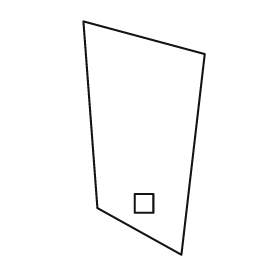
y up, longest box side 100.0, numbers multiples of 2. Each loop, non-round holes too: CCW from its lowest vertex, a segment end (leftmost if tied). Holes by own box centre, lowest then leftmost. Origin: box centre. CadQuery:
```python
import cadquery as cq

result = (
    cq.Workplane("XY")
    .moveTo(16.0, -50.0)
    .lineTo(26.0, 36.0)
    .lineTo(-26.0, 50.0)
    .lineTo(-20.0, -30.0)
    .close()
    .moveTo(-4.0, -32.0)
    .lineTo(4.0, -32.0)
    .lineTo(4.0, -24.0)
    .lineTo(-4.0, -24.0)
    .close()
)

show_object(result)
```